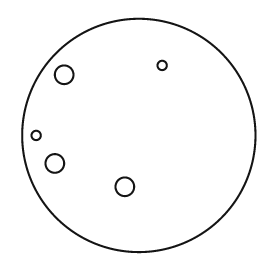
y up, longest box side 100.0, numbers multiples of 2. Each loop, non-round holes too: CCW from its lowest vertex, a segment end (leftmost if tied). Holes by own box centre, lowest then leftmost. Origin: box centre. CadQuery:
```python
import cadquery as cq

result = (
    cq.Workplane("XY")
    .moveTo(0.0, 0.0)
    .circle(50.0)
    .moveTo(-6.0, -22.0)
    .circle(4.0)
    .moveTo(-36.0, -12.0)
    .circle(4.0)
    .moveTo(-44.0, 0.0)
    .circle(2.0)
    .moveTo(-32.0, 26.0)
    .circle(4.0)
    .moveTo(10.0, 30.0)
    .circle(2.0)
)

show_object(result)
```